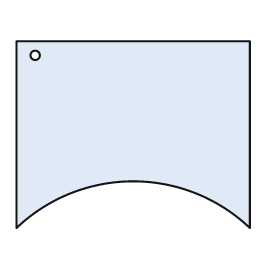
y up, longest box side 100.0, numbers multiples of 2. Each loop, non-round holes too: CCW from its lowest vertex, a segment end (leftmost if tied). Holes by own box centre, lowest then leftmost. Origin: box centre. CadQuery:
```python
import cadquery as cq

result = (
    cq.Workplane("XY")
    .moveTo(-50.0, -40.0)
    .threePointArc((0.0, -20.0), (50.0, -40.0))
    .lineTo(50.0, 40.0)
    .lineTo(-50.0, 40.0)
    .close()
    .moveTo(-42.0, 34.0)
    .circle(2.0)
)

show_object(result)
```